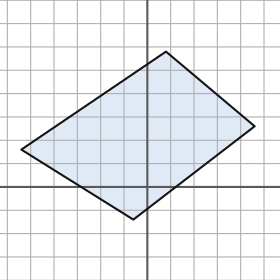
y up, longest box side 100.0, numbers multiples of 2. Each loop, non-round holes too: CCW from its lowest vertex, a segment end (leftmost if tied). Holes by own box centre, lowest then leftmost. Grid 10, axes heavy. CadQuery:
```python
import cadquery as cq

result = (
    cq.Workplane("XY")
    .moveTo(-6.0, -14.0)
    .lineTo(46.0, 26.0)
    .lineTo(8.0, 58.0)
    .lineTo(-54.0, 16.0)
    .close()
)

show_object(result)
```